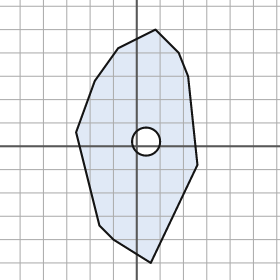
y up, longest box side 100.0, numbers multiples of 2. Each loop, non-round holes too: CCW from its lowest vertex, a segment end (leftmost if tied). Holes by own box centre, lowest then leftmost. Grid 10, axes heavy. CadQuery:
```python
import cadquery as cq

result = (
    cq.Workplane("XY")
    .moveTo(6.0, -50.0)
    .lineTo(26.0, -8.0)
    .lineTo(22.0, 30.0)
    .lineTo(18.0, 40.0)
    .lineTo(8.0, 50.0)
    .lineTo(-8.0, 42.0)
    .lineTo(-18.0, 28.0)
    .lineTo(-26.0, 6.0)
    .lineTo(-16.0, -34.0)
    .lineTo(-10.0, -40.0)
    .close()
    .moveTo(4.0, 2.0)
    .circle(6.0)
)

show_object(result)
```